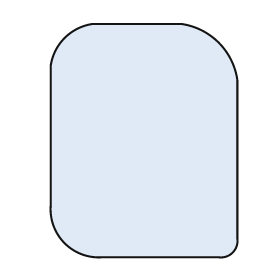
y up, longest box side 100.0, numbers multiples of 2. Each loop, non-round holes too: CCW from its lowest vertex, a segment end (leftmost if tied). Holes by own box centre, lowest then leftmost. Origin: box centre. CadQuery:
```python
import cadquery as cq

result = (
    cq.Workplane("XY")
    .moveTo(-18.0, -50.0)
    .lineTo(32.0, -50.0)
    .threePointArc((38.0, -48.0), (40.0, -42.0))
    .lineTo(40.0, 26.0)
    .threePointArc((32.0, 42.0), (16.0, 50.0))
    .lineTo(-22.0, 50.0)
    .threePointArc((-34.0, 44.0), (-40.0, 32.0))
    .lineTo(-40.0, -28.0)
    .threePointArc((-34.0, -44.0), (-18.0, -50.0))
    .close()
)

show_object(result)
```